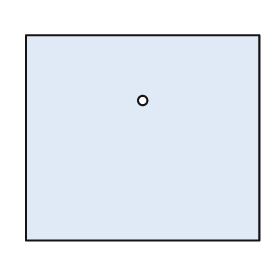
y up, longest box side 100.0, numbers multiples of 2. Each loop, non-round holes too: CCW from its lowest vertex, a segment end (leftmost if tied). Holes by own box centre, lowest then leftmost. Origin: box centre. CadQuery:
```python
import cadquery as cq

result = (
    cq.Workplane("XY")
    .moveTo(-50.0, -44.0)
    .lineTo(50.0, -44.0)
    .lineTo(50.0, 44.0)
    .lineTo(-50.0, 44.0)
    .close()
    .moveTo(0.0, 16.0)
    .circle(2.0)
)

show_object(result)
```